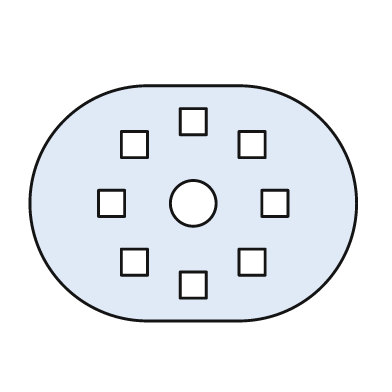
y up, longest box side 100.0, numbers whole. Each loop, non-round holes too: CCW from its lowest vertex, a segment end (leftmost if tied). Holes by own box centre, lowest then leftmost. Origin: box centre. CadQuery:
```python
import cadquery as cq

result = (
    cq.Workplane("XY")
    .moveTo(-14.0, -36.0)
    .lineTo(14.0, -36.0)
    .threePointArc((50.0, 0.0), (14.0, 36.0))
    .lineTo(-14.0, 36.0)
    .threePointArc((-50.0, 0.0), (-14.0, -36.0))
    .close()
    .moveTo(-4.0, -29.0)
    .lineTo(4.0, -29.0)
    .lineTo(4.0, -21.0)
    .lineTo(-4.0, -21.0)
    .close()
    .moveTo(-22.0, -22.0)
    .lineTo(-14.0, -22.0)
    .lineTo(-14.0, -14.0)
    .lineTo(-22.0, -14.0)
    .close()
    .moveTo(14.0, -22.0)
    .lineTo(22.0, -22.0)
    .lineTo(22.0, -14.0)
    .lineTo(14.0, -14.0)
    .close()
    .moveTo(-29.0, -4.0)
    .lineTo(-21.0, -4.0)
    .lineTo(-21.0, 4.0)
    .lineTo(-29.0, 4.0)
    .close()
    .moveTo(0.0, 0.0)
    .circle(7.0)
    .moveTo(21.0, -4.0)
    .lineTo(29.0, -4.0)
    .lineTo(29.0, 4.0)
    .lineTo(21.0, 4.0)
    .close()
    .moveTo(-22.0, 14.0)
    .lineTo(-14.0, 14.0)
    .lineTo(-14.0, 22.0)
    .lineTo(-22.0, 22.0)
    .close()
    .moveTo(14.0, 14.0)
    .lineTo(22.0, 14.0)
    .lineTo(22.0, 22.0)
    .lineTo(14.0, 22.0)
    .close()
    .moveTo(-4.0, 21.0)
    .lineTo(4.0, 21.0)
    .lineTo(4.0, 29.0)
    .lineTo(-4.0, 29.0)
    .close()
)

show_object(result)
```